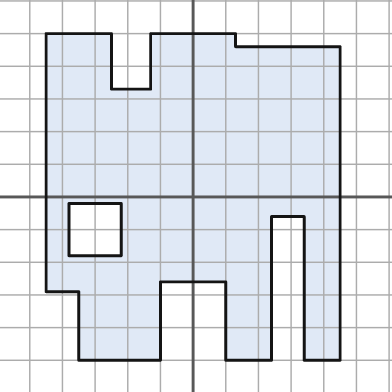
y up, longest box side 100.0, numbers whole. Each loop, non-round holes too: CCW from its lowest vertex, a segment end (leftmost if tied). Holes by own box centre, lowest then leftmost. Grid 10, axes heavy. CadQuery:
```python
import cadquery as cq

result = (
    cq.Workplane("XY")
    .moveTo(-35.0, -50.0)
    .lineTo(-10.0, -50.0)
    .lineTo(-10.0, -26.0)
    .lineTo(10.0, -26.0)
    .lineTo(10.0, -50.0)
    .lineTo(24.0, -50.0)
    .lineTo(24.0, -6.0)
    .lineTo(34.0, -6.0)
    .lineTo(34.0, -50.0)
    .lineTo(45.0, -50.0)
    .lineTo(45.0, 46.0)
    .lineTo(13.0, 46.0)
    .lineTo(13.0, 50.0)
    .lineTo(-13.0, 50.0)
    .lineTo(-13.0, 33.0)
    .lineTo(-25.0, 33.0)
    .lineTo(-25.0, 50.0)
    .lineTo(-45.0, 50.0)
    .lineTo(-45.0, -29.0)
    .lineTo(-35.0, -29.0)
    .close()
    .moveTo(-38.0, -18.0)
    .lineTo(-22.0, -18.0)
    .lineTo(-22.0, -2.0)
    .lineTo(-38.0, -2.0)
    .close()
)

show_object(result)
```